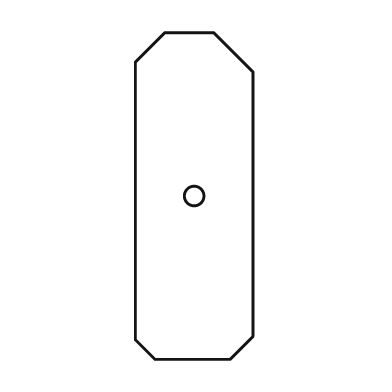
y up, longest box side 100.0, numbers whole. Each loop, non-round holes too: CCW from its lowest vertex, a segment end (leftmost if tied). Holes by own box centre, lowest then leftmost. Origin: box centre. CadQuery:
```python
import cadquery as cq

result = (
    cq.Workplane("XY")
    .moveTo(-12.0, -50.0)
    .lineTo(11.0, -50.0)
    .lineTo(18.0, -43.0)
    .lineTo(18.0, 38.0)
    .lineTo(6.0, 50.0)
    .lineTo(-9.0, 50.0)
    .lineTo(-18.0, 41.0)
    .lineTo(-18.0, -44.0)
    .close()
    .moveTo(0.0, 0.0)
    .circle(3.0)
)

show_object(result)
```